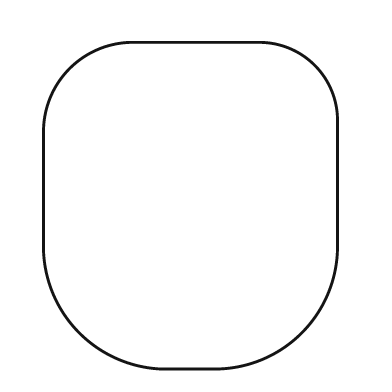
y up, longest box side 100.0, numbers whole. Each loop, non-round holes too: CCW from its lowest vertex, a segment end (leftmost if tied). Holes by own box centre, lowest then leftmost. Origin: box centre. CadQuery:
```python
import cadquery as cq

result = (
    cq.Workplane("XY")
    .moveTo(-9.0, -50.0)
    .lineTo(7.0, -50.0)
    .threePointArc((34.0, -39.0), (45.0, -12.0))
    .lineTo(45.0, 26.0)
    .threePointArc((38.0, 43.0), (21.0, 50.0))
    .lineTo(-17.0, 50.0)
    .threePointArc((-37.0, 42.0), (-45.0, 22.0))
    .lineTo(-45.0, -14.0)
    .threePointArc((-34.0, -39.0), (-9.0, -50.0))
    .close()
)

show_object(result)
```